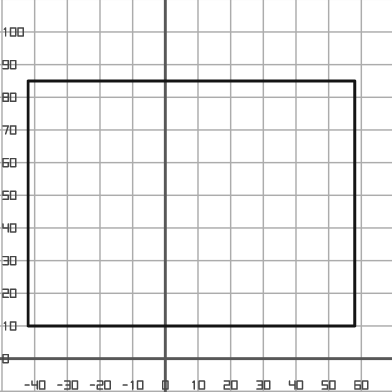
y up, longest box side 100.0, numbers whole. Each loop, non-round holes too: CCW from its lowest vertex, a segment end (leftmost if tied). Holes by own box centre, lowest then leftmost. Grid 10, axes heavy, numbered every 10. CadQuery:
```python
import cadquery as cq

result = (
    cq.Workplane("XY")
    .moveTo(-42.0, 10.0)
    .lineTo(58.0, 10.0)
    .lineTo(58.0, 85.0)
    .lineTo(-42.0, 85.0)
    .close()
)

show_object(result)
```